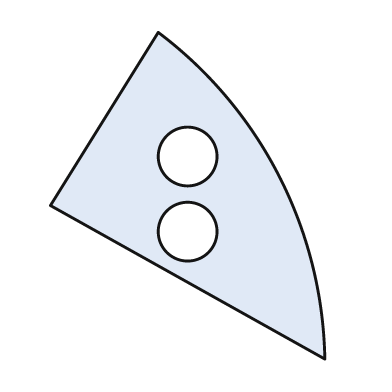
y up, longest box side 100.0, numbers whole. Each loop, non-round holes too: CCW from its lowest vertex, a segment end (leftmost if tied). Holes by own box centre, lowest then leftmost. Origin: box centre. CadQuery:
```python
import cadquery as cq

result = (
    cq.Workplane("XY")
    .moveTo(42.0, -50.0)
    .threePointArc((28.0, 6.0), (-9.0, 50.0))
    .lineTo(-42.0, -3.0)
    .close()
    .moveTo(0.0, -11.0)
    .circle(9.0)
    .moveTo(0.0, 12.0)
    .circle(9.0)
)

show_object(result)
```